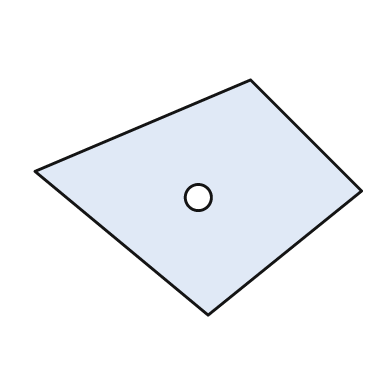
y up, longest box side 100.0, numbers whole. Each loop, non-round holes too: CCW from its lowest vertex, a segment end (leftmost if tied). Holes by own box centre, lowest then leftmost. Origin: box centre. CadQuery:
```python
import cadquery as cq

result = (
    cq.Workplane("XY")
    .moveTo(3.0, -36.0)
    .lineTo(50.0, 2.0)
    .lineTo(16.0, 36.0)
    .lineTo(-50.0, 8.0)
    .close()
    .moveTo(0.0, 0.0)
    .circle(4.0)
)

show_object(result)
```